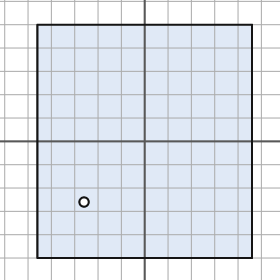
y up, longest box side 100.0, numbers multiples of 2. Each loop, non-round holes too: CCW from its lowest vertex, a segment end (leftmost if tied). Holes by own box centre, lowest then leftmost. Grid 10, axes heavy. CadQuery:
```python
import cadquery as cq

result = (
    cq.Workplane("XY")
    .moveTo(-46.0, -50.0)
    .lineTo(46.0, -50.0)
    .lineTo(46.0, 50.0)
    .lineTo(-46.0, 50.0)
    .close()
    .moveTo(-26.0, -26.0)
    .circle(2.0)
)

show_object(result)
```